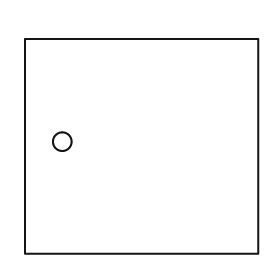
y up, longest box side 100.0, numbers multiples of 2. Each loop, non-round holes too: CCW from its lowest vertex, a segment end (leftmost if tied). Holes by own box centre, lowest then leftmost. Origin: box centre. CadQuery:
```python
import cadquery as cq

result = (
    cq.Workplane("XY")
    .moveTo(-50.0, -46.0)
    .lineTo(50.0, -46.0)
    .lineTo(50.0, 46.0)
    .lineTo(-50.0, 46.0)
    .close()
    .moveTo(-34.0, 2.0)
    .circle(4.0)
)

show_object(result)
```